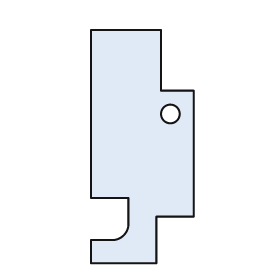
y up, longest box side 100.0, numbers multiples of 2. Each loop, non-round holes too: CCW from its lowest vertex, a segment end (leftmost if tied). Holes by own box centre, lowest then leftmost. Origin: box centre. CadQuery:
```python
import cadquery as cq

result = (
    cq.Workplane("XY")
    .moveTo(-22.0, -50.0)
    .lineTo(6.0, -50.0)
    .lineTo(6.0, -30.0)
    .lineTo(22.0, -30.0)
    .lineTo(22.0, 24.0)
    .lineTo(8.0, 24.0)
    .lineTo(8.0, 50.0)
    .lineTo(-22.0, 50.0)
    .lineTo(-22.0, -22.0)
    .lineTo(-6.0, -22.0)
    .lineTo(-6.0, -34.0)
    .threePointArc((-8.0, -38.0), (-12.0, -40.0))
    .lineTo(-22.0, -40.0)
    .close()
    .moveTo(12.0, 14.0)
    .circle(4.0)
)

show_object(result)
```